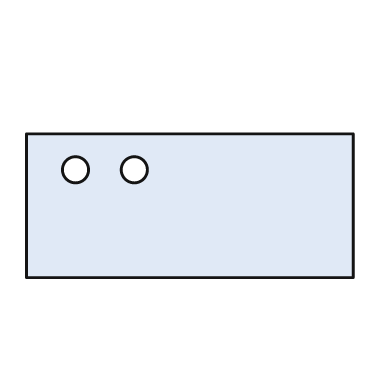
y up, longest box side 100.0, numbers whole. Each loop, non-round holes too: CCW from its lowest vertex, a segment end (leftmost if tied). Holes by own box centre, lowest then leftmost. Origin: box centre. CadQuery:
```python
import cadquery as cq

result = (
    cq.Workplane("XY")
    .moveTo(-50.0, -22.0)
    .lineTo(50.0, -22.0)
    .lineTo(50.0, 22.0)
    .lineTo(-50.0, 22.0)
    .close()
    .moveTo(-35.0, 11.0)
    .circle(4.0)
    .moveTo(-17.0, 11.0)
    .circle(4.0)
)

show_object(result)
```